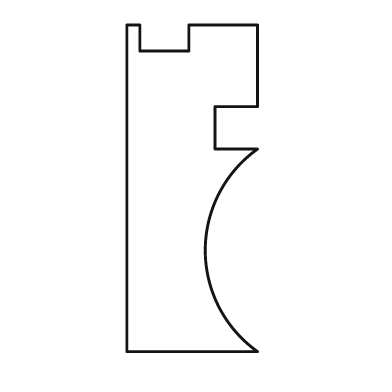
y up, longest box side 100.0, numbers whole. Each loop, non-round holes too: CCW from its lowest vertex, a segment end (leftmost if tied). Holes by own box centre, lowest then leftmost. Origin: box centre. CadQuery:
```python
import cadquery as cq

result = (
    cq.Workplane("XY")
    .moveTo(-20.0, -50.0)
    .lineTo(20.0, -50.0)
    .threePointArc((4.0, -19.0), (20.0, 12.0))
    .lineTo(7.0, 12.0)
    .lineTo(7.0, 25.0)
    .lineTo(20.0, 25.0)
    .lineTo(20.0, 50.0)
    .lineTo(-1.0, 50.0)
    .lineTo(-1.0, 42.0)
    .lineTo(-16.0, 42.0)
    .lineTo(-16.0, 50.0)
    .lineTo(-20.0, 50.0)
    .close()
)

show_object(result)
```